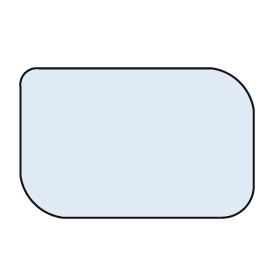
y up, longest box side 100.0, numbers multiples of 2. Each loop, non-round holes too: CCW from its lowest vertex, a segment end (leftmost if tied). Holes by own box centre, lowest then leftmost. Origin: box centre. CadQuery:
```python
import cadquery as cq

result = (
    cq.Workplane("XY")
    .moveTo(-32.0, -32.0)
    .lineTo(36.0, -32.0)
    .threePointArc((46.0, -28.0), (50.0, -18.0))
    .lineTo(50.0, 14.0)
    .threePointArc((44.0, 26.0), (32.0, 32.0))
    .lineTo(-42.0, 32.0)
    .threePointArc((-48.0, 30.0), (-50.0, 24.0))
    .lineTo(-50.0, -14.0)
    .threePointArc((-44.0, -26.0), (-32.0, -32.0))
    .close()
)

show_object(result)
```